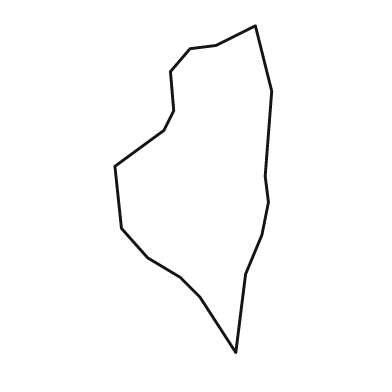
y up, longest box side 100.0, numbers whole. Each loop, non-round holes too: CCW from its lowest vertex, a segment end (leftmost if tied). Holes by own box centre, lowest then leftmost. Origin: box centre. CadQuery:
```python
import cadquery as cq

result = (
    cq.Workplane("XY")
    .moveTo(13.0, -50.0)
    .lineTo(16.0, -26.0)
    .lineTo(21.0, -14.0)
    .lineTo(23.0, -4.0)
    .lineTo(22.0, 4.0)
    .lineTo(24.0, 30.0)
    .lineTo(19.0, 50.0)
    .lineTo(7.0, 44.0)
    .lineTo(-1.0, 43.0)
    .lineTo(-7.0, 36.0)
    .lineTo(-6.0, 24.0)
    .lineTo(-9.0, 18.0)
    .lineTo(-24.0, 7.0)
    .lineTo(-22.0, -12.0)
    .lineTo(-14.0, -21.0)
    .lineTo(-4.0, -27.0)
    .lineTo(2.0, -33.0)
    .close()
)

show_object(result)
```